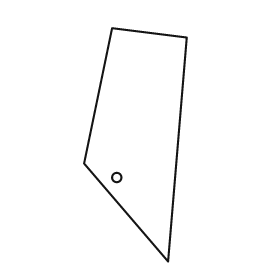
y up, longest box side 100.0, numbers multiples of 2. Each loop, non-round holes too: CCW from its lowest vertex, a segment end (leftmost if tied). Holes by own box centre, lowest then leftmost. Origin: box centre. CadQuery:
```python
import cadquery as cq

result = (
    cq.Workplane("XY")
    .moveTo(14.0, -50.0)
    .lineTo(22.0, 46.0)
    .lineTo(-10.0, 50.0)
    .lineTo(-22.0, -8.0)
    .close()
    .moveTo(-8.0, -14.0)
    .circle(2.0)
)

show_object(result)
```